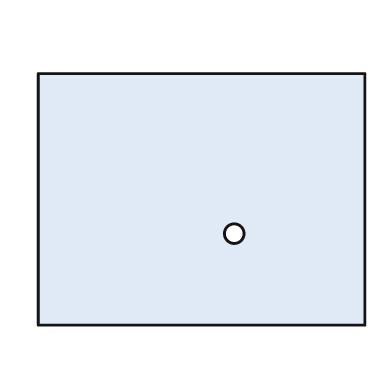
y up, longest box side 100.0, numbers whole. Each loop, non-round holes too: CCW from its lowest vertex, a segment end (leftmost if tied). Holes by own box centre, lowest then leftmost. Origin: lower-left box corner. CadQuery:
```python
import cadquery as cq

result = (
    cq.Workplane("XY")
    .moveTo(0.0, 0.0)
    .lineTo(100.0, 0.0)
    .lineTo(100.0, 77.0)
    .lineTo(0.0, 77.0)
    .close()
    .moveTo(60.0, 28.0)
    .circle(3.0)
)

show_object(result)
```